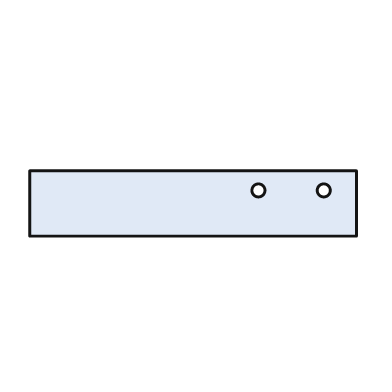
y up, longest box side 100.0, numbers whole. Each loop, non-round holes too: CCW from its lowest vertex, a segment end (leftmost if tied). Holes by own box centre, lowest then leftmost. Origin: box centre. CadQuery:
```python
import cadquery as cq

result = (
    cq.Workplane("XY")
    .moveTo(-50.0, -10.0)
    .lineTo(50.0, -10.0)
    .lineTo(50.0, 10.0)
    .lineTo(-50.0, 10.0)
    .close()
    .moveTo(20.0, 4.0)
    .circle(2.0)
    .moveTo(40.0, 4.0)
    .circle(2.0)
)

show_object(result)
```